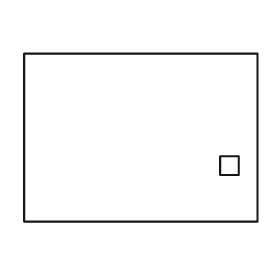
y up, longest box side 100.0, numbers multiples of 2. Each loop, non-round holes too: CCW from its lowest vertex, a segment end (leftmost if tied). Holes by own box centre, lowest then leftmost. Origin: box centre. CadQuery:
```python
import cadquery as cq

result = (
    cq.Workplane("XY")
    .moveTo(-50.0, -36.0)
    .lineTo(50.0, -36.0)
    .lineTo(50.0, 36.0)
    .lineTo(-50.0, 36.0)
    .close()
    .moveTo(34.0, -16.0)
    .lineTo(42.0, -16.0)
    .lineTo(42.0, -8.0)
    .lineTo(34.0, -8.0)
    .close()
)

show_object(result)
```